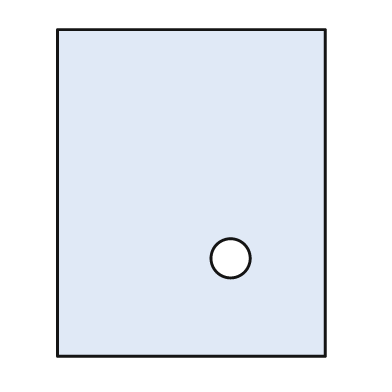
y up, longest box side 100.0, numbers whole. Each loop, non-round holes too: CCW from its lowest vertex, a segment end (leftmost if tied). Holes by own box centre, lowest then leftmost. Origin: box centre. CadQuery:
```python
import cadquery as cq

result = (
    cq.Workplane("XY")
    .moveTo(-41.0, -50.0)
    .lineTo(41.0, -50.0)
    .lineTo(41.0, 50.0)
    .lineTo(-41.0, 50.0)
    .close()
    .moveTo(12.0, -20.0)
    .circle(6.0)
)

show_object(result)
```